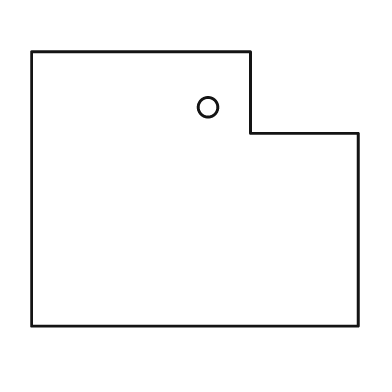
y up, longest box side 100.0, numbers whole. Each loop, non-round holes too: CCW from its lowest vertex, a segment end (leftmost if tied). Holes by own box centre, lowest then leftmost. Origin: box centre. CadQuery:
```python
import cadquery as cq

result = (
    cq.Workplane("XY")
    .moveTo(-50.0, -42.0)
    .lineTo(50.0, -42.0)
    .lineTo(50.0, 17.0)
    .lineTo(17.0, 17.0)
    .lineTo(17.0, 42.0)
    .lineTo(-50.0, 42.0)
    .close()
    .moveTo(4.0, 25.0)
    .circle(3.0)
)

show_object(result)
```